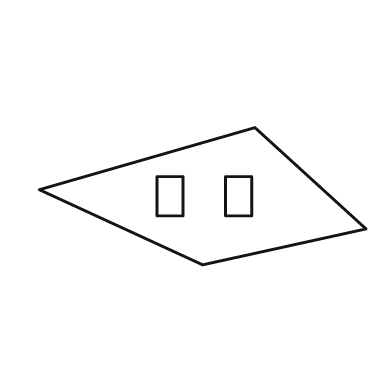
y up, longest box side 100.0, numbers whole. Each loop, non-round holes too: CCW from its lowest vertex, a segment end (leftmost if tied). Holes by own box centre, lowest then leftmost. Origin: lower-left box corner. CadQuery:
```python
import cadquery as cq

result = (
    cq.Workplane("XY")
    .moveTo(50.0, 0.0)
    .lineTo(100.0, 11.0)
    .lineTo(66.0, 42.0)
    .lineTo(0.0, 23.0)
    .close()
    .moveTo(36.0, 15.0)
    .lineTo(44.0, 15.0)
    .lineTo(44.0, 27.0)
    .lineTo(36.0, 27.0)
    .close()
    .moveTo(57.0, 15.0)
    .lineTo(65.0, 15.0)
    .lineTo(65.0, 27.0)
    .lineTo(57.0, 27.0)
    .close()
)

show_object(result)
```